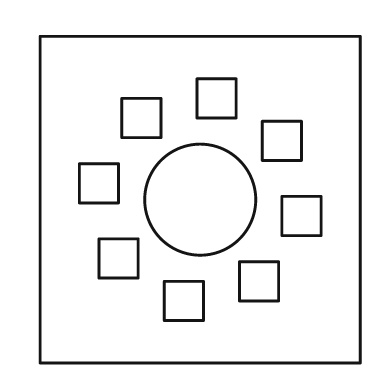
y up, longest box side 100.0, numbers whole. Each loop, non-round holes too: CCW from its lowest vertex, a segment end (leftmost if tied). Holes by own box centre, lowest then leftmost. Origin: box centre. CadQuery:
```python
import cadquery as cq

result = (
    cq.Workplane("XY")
    .moveTo(-49.0, -50.0)
    .lineTo(49.0, -50.0)
    .lineTo(49.0, 50.0)
    .lineTo(-49.0, 50.0)
    .close()
    .moveTo(-11.0, -37.0)
    .lineTo(1.0, -37.0)
    .lineTo(1.0, -25.0)
    .lineTo(-11.0, -25.0)
    .close()
    .moveTo(12.0, -31.0)
    .lineTo(24.0, -31.0)
    .lineTo(24.0, -19.0)
    .lineTo(12.0, -19.0)
    .close()
    .moveTo(-31.0, -24.0)
    .lineTo(-19.0, -24.0)
    .lineTo(-19.0, -12.0)
    .lineTo(-31.0, -12.0)
    .close()
    .moveTo(25.0, -11.0)
    .lineTo(37.0, -11.0)
    .lineTo(37.0, 1.0)
    .lineTo(25.0, 1.0)
    .close()
    .moveTo(0.0, 0.0)
    .circle(17.0)
    .moveTo(-37.0, -1.0)
    .lineTo(-25.0, -1.0)
    .lineTo(-25.0, 11.0)
    .lineTo(-37.0, 11.0)
    .close()
    .moveTo(19.0, 12.0)
    .lineTo(31.0, 12.0)
    .lineTo(31.0, 24.0)
    .lineTo(19.0, 24.0)
    .close()
    .moveTo(-24.0, 19.0)
    .lineTo(-12.0, 19.0)
    .lineTo(-12.0, 31.0)
    .lineTo(-24.0, 31.0)
    .close()
    .moveTo(-1.0, 25.0)
    .lineTo(11.0, 25.0)
    .lineTo(11.0, 37.0)
    .lineTo(-1.0, 37.0)
    .close()
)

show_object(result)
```